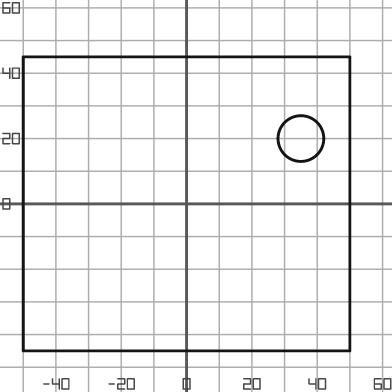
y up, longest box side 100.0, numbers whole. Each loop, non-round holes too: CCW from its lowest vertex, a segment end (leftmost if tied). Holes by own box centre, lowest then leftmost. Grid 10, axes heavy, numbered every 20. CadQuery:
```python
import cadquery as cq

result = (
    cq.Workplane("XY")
    .moveTo(-50.0, -45.0)
    .lineTo(50.0, -45.0)
    .lineTo(50.0, 45.0)
    .lineTo(-50.0, 45.0)
    .close()
    .moveTo(35.0, 20.0)
    .circle(7.0)
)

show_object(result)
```